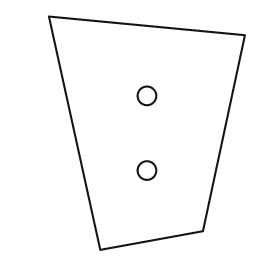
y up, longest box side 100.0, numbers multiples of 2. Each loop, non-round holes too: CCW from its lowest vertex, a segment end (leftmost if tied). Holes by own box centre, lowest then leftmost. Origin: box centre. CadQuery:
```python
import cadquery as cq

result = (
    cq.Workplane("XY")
    .moveTo(-20.0, -50.0)
    .lineTo(24.0, -42.0)
    .lineTo(42.0, 42.0)
    .lineTo(-42.0, 50.0)
    .close()
    .moveTo(0.0, -16.0)
    .circle(4.0)
    .moveTo(0.0, 16.0)
    .circle(4.0)
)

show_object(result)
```